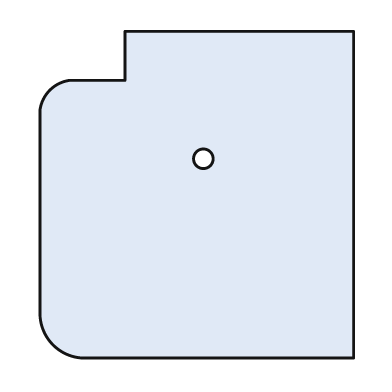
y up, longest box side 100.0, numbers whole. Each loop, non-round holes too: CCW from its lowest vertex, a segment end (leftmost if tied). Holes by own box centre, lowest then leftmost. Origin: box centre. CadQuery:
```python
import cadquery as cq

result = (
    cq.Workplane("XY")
    .moveTo(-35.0, -50.0)
    .lineTo(48.0, -50.0)
    .lineTo(48.0, 50.0)
    .lineTo(-22.0, 50.0)
    .lineTo(-22.0, 35.0)
    .lineTo(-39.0, 35.0)
    .threePointArc((-45.0, 32.0), (-48.0, 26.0))
    .lineTo(-48.0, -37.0)
    .threePointArc((-44.0, -46.0), (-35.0, -50.0))
    .close()
    .moveTo(2.0, 11.0)
    .circle(3.0)
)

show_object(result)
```